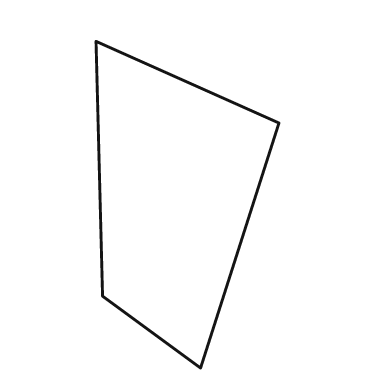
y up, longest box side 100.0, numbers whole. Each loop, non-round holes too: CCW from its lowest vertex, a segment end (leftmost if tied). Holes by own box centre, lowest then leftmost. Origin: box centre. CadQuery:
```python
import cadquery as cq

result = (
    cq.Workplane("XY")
    .moveTo(4.0, -50.0)
    .lineTo(28.0, 25.0)
    .lineTo(-28.0, 50.0)
    .lineTo(-26.0, -28.0)
    .close()
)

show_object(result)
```